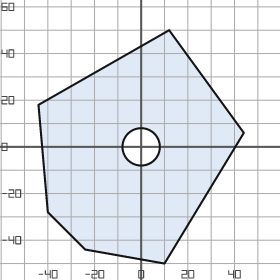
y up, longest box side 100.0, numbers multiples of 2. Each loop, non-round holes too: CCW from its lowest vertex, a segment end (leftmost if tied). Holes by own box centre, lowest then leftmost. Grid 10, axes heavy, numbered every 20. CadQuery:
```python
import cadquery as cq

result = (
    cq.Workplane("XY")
    .moveTo(10.0, -50.0)
    .lineTo(44.0, 6.0)
    .lineTo(12.0, 50.0)
    .lineTo(-44.0, 18.0)
    .lineTo(-40.0, -28.0)
    .lineTo(-24.0, -44.0)
    .close()
    .moveTo(0.0, 0.0)
    .circle(8.0)
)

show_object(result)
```